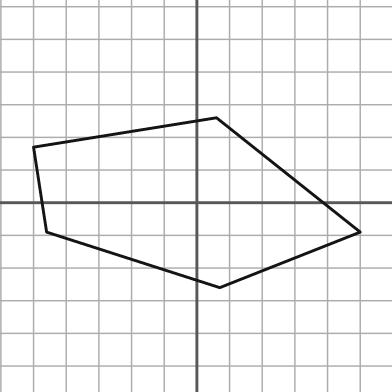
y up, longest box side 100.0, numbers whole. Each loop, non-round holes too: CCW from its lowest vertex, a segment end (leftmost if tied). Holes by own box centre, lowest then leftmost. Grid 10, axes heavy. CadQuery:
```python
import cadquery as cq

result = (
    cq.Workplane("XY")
    .moveTo(7.0, -26.0)
    .lineTo(50.0, -9.0)
    .lineTo(6.0, 26.0)
    .lineTo(-50.0, 17.0)
    .lineTo(-46.0, -9.0)
    .close()
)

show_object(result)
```